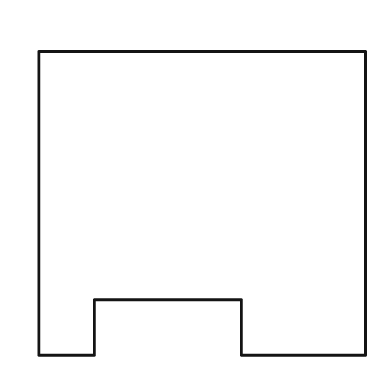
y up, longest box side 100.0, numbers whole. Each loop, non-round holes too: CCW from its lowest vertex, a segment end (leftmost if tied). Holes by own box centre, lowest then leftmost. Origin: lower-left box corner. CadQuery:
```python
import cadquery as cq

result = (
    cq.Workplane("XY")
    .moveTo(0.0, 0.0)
    .lineTo(17.0, 0.0)
    .lineTo(17.0, 17.0)
    .lineTo(62.0, 17.0)
    .lineTo(62.0, 0.0)
    .lineTo(100.0, 0.0)
    .lineTo(100.0, 93.0)
    .lineTo(0.0, 93.0)
    .close()
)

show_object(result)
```